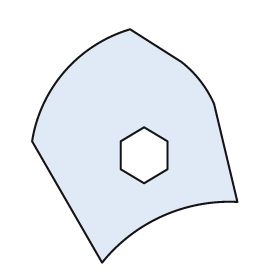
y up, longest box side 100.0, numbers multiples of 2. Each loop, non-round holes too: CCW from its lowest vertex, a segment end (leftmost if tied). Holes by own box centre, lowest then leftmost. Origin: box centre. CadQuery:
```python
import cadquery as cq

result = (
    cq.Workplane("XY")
    .moveTo(-14.0, -50.0)
    .threePointArc((12.0, -30.0), (44.0, -24.0))
    .lineTo(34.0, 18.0)
    .threePointArc((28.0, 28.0), (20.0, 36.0))
    .lineTo(-2.0, 50.0)
    .threePointArc((-30.0, 32.0), (-44.0, 2.0))
    .close()
    .moveTo(4.0, -16.0)
    .lineTo(14.0, -10.0)
    .lineTo(14.0, 2.0)
    .lineTo(4.0, 8.0)
    .lineTo(-6.0, 2.0)
    .lineTo(-6.0, -10.0)
    .close()
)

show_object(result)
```